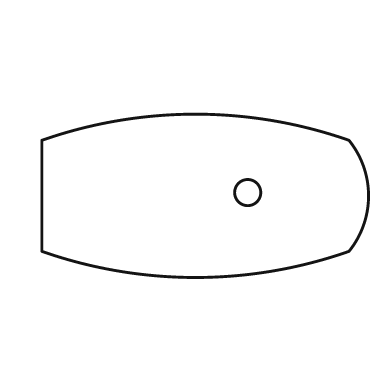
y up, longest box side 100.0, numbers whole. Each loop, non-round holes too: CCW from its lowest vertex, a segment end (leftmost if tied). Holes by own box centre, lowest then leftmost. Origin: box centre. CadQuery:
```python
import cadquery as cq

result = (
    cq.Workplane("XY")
    .moveTo(-50.0, -17.0)
    .threePointArc((-3.0, -25.0), (44.0, -17.0))
    .threePointArc((50.0, 0.0), (44.0, 17.0))
    .threePointArc((-3.0, 25.0), (-50.0, 17.0))
    .close()
    .moveTo(13.0, 1.0)
    .circle(4.0)
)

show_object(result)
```